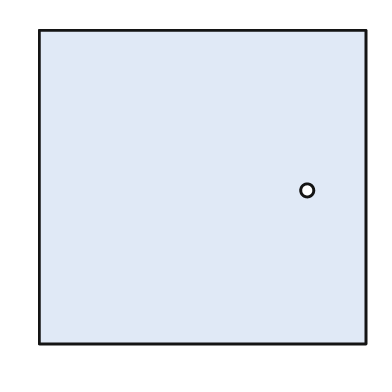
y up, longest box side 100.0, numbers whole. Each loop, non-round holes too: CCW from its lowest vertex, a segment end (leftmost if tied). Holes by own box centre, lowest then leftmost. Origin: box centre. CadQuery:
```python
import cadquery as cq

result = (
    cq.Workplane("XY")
    .moveTo(-50.0, -48.0)
    .lineTo(50.0, -48.0)
    .lineTo(50.0, 48.0)
    .lineTo(-50.0, 48.0)
    .close()
    .moveTo(32.0, -1.0)
    .circle(2.0)
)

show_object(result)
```